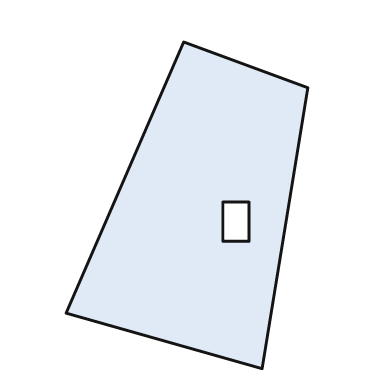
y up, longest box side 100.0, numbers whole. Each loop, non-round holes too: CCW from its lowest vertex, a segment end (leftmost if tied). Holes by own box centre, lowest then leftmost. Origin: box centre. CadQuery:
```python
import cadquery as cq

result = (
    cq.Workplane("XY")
    .moveTo(23.0, -50.0)
    .lineTo(37.0, 36.0)
    .lineTo(-1.0, 50.0)
    .lineTo(-37.0, -33.0)
    .close()
    .moveTo(11.0, -11.0)
    .lineTo(19.0, -11.0)
    .lineTo(19.0, 1.0)
    .lineTo(11.0, 1.0)
    .close()
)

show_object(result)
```